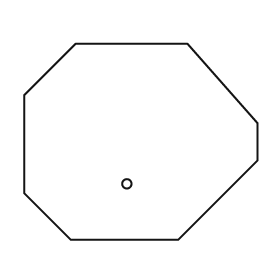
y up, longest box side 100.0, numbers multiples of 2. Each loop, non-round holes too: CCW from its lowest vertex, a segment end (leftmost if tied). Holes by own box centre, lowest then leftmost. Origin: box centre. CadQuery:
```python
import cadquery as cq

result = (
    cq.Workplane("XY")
    .moveTo(-30.0, -42.0)
    .lineTo(16.0, -42.0)
    .lineTo(50.0, -8.0)
    .lineTo(50.0, 8.0)
    .lineTo(20.0, 42.0)
    .lineTo(-28.0, 42.0)
    .lineTo(-50.0, 20.0)
    .lineTo(-50.0, -22.0)
    .close()
    .moveTo(-6.0, -18.0)
    .circle(2.0)
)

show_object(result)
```